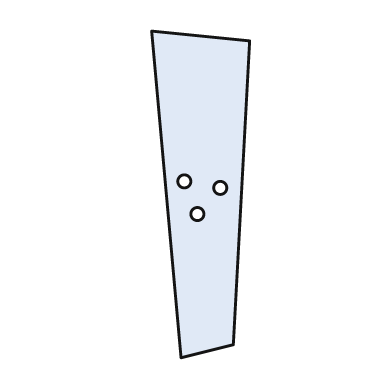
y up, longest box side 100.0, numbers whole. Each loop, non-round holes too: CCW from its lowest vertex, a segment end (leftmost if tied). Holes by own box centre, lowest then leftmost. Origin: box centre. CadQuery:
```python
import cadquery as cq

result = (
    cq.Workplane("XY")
    .moveTo(-6.0, -50.0)
    .lineTo(10.0, -46.0)
    .lineTo(15.0, 47.0)
    .lineTo(-15.0, 50.0)
    .close()
    .moveTo(-1.0, -6.0)
    .circle(2.0)
    .moveTo(6.0, 2.0)
    .circle(2.0)
    .moveTo(-5.0, 4.0)
    .circle(2.0)
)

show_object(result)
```